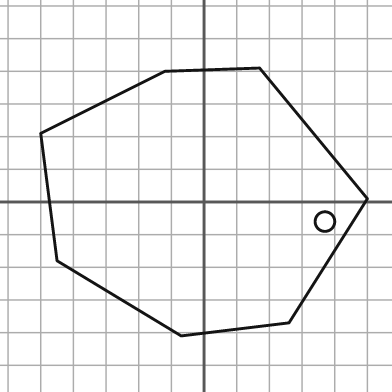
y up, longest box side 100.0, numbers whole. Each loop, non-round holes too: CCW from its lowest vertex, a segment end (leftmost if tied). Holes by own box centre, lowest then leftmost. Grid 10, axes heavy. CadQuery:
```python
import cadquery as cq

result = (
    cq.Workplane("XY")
    .moveTo(-7.0, -41.0)
    .lineTo(26.0, -37.0)
    .lineTo(50.0, 1.0)
    .lineTo(17.0, 41.0)
    .lineTo(-12.0, 40.0)
    .lineTo(-50.0, 21.0)
    .lineTo(-45.0, -18.0)
    .close()
    .moveTo(37.0, -6.0)
    .circle(3.0)
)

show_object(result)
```